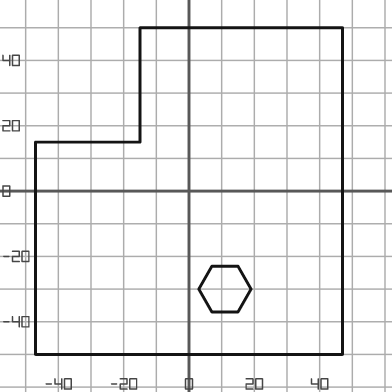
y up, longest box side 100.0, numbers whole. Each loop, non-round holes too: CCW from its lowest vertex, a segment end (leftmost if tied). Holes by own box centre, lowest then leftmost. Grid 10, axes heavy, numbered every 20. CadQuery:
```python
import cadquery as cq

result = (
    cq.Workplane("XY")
    .moveTo(-47.0, -50.0)
    .lineTo(47.0, -50.0)
    .lineTo(47.0, 50.0)
    .lineTo(-15.0, 50.0)
    .lineTo(-15.0, 15.0)
    .lineTo(-47.0, 15.0)
    .close()
    .moveTo(7.0, -37.0)
    .lineTo(15.0, -37.0)
    .lineTo(19.0, -30.0)
    .lineTo(15.0, -23.0)
    .lineTo(7.0, -23.0)
    .lineTo(3.0, -30.0)
    .close()
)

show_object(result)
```